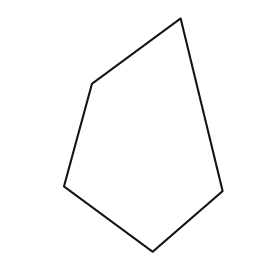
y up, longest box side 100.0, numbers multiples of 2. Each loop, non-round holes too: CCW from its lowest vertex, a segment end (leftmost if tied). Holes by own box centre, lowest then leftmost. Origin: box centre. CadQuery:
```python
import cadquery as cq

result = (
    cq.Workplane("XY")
    .moveTo(4.0, -50.0)
    .lineTo(34.0, -24.0)
    .lineTo(16.0, 50.0)
    .lineTo(-22.0, 22.0)
    .lineTo(-34.0, -22.0)
    .close()
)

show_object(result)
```